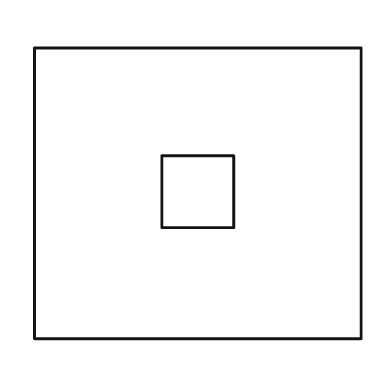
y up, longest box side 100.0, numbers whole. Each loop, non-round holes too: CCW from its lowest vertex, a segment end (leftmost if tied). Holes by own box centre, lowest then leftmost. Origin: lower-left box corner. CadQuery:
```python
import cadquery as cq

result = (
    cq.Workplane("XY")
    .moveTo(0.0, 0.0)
    .lineTo(100.0, 0.0)
    .lineTo(100.0, 89.0)
    .lineTo(0.0, 89.0)
    .close()
    .moveTo(39.0, 34.0)
    .lineTo(61.0, 34.0)
    .lineTo(61.0, 56.0)
    .lineTo(39.0, 56.0)
    .close()
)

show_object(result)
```